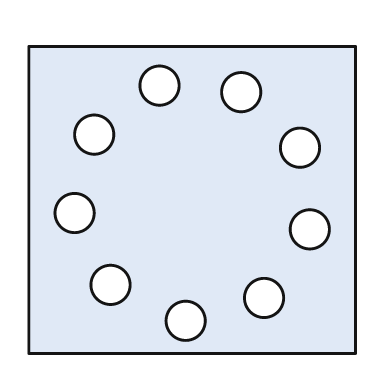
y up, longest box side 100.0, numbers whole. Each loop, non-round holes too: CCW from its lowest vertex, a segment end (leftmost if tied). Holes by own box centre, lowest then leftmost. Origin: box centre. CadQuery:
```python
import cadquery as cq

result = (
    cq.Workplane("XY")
    .moveTo(-50.0, -47.0)
    .lineTo(50.0, -47.0)
    .lineTo(50.0, 47.0)
    .lineTo(-50.0, 47.0)
    .close()
    .moveTo(-2.0, -37.0)
    .circle(6.0)
    .moveTo(22.0, -30.0)
    .circle(6.0)
    .moveTo(-25.0, -26.0)
    .circle(6.0)
    .moveTo(36.0, -9.0)
    .circle(6.0)
    .moveTo(-36.0, -4.0)
    .circle(6.0)
    .moveTo(33.0, 16.0)
    .circle(6.0)
    .moveTo(-30.0, 20.0)
    .circle(6.0)
    .moveTo(15.0, 33.0)
    .circle(6.0)
    .moveTo(-10.0, 35.0)
    .circle(6.0)
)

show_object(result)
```